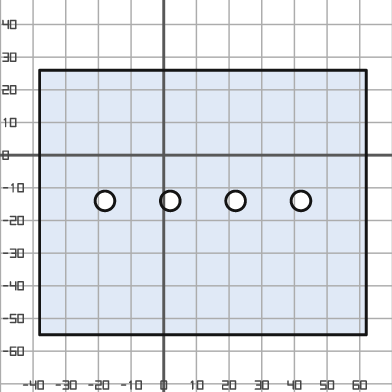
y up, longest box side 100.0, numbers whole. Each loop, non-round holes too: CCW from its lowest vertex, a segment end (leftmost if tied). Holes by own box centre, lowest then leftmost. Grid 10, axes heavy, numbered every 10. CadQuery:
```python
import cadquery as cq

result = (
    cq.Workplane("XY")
    .moveTo(-38.0, -55.0)
    .lineTo(62.0, -55.0)
    .lineTo(62.0, 26.0)
    .lineTo(-38.0, 26.0)
    .close()
    .moveTo(-18.0, -14.0)
    .circle(3.0)
    .moveTo(2.0, -14.0)
    .circle(3.0)
    .moveTo(22.0, -14.0)
    .circle(3.0)
    .moveTo(42.0, -14.0)
    .circle(3.0)
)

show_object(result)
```